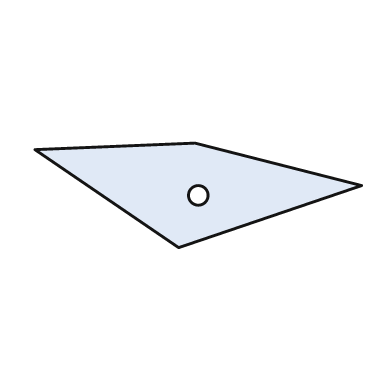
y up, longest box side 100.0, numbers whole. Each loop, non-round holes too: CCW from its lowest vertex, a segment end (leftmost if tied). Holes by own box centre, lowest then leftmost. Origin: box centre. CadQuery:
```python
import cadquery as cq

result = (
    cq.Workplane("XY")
    .moveTo(-6.0, -16.0)
    .lineTo(50.0, 3.0)
    .lineTo(-1.0, 16.0)
    .lineTo(-50.0, 14.0)
    .close()
    .moveTo(0.0, 0.0)
    .circle(3.0)
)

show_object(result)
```